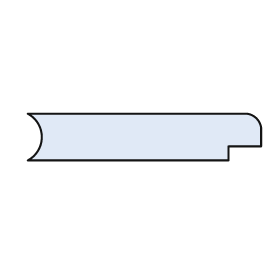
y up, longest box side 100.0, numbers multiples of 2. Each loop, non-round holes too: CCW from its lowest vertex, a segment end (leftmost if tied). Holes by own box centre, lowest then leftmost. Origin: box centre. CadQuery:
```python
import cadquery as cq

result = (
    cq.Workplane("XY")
    .moveTo(-50.0, -10.0)
    .lineTo(36.0, -10.0)
    .lineTo(36.0, -4.0)
    .lineTo(50.0, -4.0)
    .lineTo(50.0, 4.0)
    .threePointArc((48.0, 8.0), (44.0, 10.0))
    .lineTo(-50.0, 10.0)
    .threePointArc((-44.0, 0.0), (-50.0, -10.0))
    .close()
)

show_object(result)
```